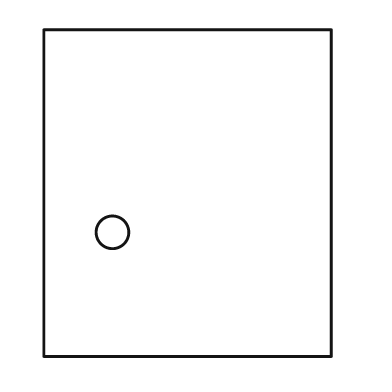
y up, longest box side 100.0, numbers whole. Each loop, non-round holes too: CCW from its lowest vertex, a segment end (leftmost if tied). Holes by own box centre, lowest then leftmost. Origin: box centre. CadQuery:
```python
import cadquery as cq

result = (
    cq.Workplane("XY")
    .moveTo(-44.0, -50.0)
    .lineTo(44.0, -50.0)
    .lineTo(44.0, 50.0)
    .lineTo(-44.0, 50.0)
    .close()
    .moveTo(-23.0, -12.0)
    .circle(5.0)
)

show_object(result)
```